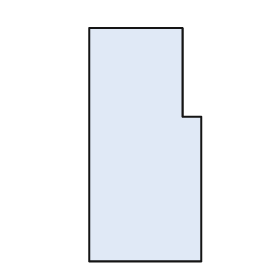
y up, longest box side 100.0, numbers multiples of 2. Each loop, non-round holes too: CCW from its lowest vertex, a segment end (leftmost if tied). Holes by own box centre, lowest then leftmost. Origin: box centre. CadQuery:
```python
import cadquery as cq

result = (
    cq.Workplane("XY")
    .moveTo(-24.0, -50.0)
    .lineTo(24.0, -50.0)
    .lineTo(24.0, 12.0)
    .lineTo(16.0, 12.0)
    .lineTo(16.0, 50.0)
    .lineTo(-24.0, 50.0)
    .close()
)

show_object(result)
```